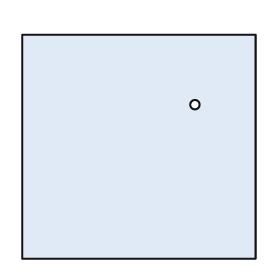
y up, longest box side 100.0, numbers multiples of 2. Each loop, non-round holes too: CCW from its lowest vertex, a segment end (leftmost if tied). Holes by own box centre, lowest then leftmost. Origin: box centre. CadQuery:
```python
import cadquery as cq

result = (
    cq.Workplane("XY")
    .moveTo(-50.0, -48.0)
    .lineTo(50.0, -48.0)
    .lineTo(50.0, 48.0)
    .lineTo(-50.0, 48.0)
    .close()
    .moveTo(24.0, 18.0)
    .circle(2.0)
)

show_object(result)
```